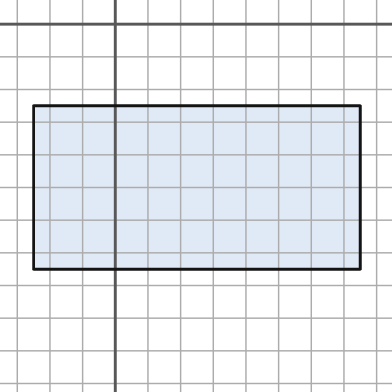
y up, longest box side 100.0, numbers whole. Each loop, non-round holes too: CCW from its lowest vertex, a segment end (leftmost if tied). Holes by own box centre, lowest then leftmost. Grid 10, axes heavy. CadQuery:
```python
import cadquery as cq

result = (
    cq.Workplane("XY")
    .moveTo(-25.0, -75.0)
    .lineTo(75.0, -75.0)
    .lineTo(75.0, -25.0)
    .lineTo(-25.0, -25.0)
    .close()
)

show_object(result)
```